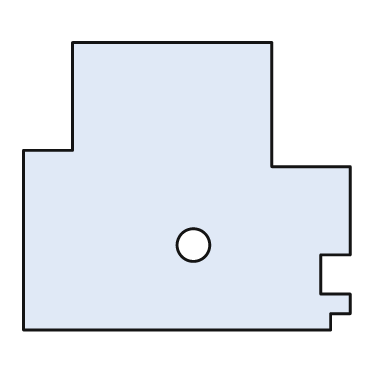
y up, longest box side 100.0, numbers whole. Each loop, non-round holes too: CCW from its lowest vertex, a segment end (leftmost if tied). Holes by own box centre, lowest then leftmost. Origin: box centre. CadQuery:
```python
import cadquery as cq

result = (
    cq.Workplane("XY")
    .moveTo(-50.0, -44.0)
    .lineTo(44.0, -44.0)
    .lineTo(44.0, -39.0)
    .lineTo(50.0, -39.0)
    .lineTo(50.0, -33.0)
    .lineTo(41.0, -33.0)
    .lineTo(41.0, -21.0)
    .lineTo(50.0, -21.0)
    .lineTo(50.0, 6.0)
    .lineTo(26.0, 6.0)
    .lineTo(26.0, 44.0)
    .lineTo(-35.0, 44.0)
    .lineTo(-35.0, 11.0)
    .lineTo(-50.0, 11.0)
    .close()
    .moveTo(2.0, -18.0)
    .circle(5.0)
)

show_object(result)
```